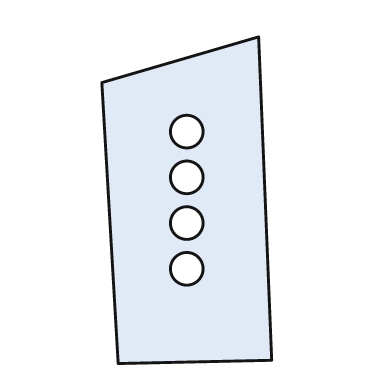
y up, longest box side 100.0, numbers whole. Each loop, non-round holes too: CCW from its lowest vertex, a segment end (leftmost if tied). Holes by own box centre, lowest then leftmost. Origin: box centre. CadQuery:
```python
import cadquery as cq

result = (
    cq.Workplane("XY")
    .moveTo(-21.0, -50.0)
    .lineTo(26.0, -49.0)
    .lineTo(22.0, 50.0)
    .lineTo(-26.0, 36.0)
    .close()
    .moveTo(0.0, -21.0)
    .circle(5.0)
    .moveTo(0.0, -7.0)
    .circle(5.0)
    .moveTo(0.0, 7.0)
    .circle(5.0)
    .moveTo(0.0, 21.0)
    .circle(5.0)
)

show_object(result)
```